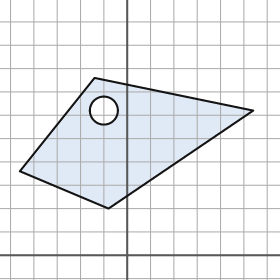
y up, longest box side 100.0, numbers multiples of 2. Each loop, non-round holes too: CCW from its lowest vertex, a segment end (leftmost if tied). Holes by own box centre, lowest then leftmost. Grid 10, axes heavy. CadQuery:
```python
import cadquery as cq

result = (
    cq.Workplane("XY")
    .moveTo(-8.0, 20.0)
    .lineTo(54.0, 62.0)
    .lineTo(-14.0, 76.0)
    .lineTo(-46.0, 36.0)
    .close()
    .moveTo(-10.0, 62.0)
    .circle(6.0)
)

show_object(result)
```